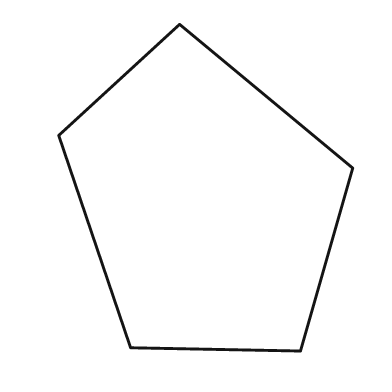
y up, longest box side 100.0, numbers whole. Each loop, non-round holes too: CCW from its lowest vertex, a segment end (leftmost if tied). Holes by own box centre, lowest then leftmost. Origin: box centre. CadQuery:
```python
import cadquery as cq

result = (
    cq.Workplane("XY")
    .moveTo(29.0, -50.0)
    .lineTo(45.0, 6.0)
    .lineTo(-8.0, 50.0)
    .lineTo(-45.0, 16.0)
    .lineTo(-23.0, -49.0)
    .close()
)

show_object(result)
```